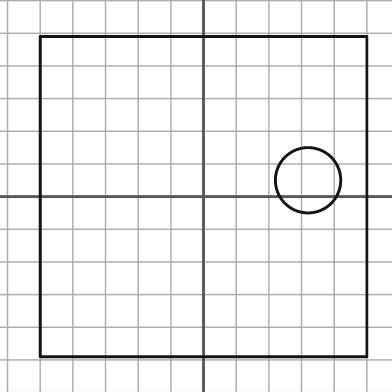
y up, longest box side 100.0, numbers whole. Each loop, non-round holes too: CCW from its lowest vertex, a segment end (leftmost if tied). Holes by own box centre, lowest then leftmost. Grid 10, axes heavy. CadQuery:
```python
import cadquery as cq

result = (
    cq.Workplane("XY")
    .moveTo(-50.0, -49.0)
    .lineTo(50.0, -49.0)
    .lineTo(50.0, 49.0)
    .lineTo(-50.0, 49.0)
    .close()
    .moveTo(32.0, 5.0)
    .circle(10.0)
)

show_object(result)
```